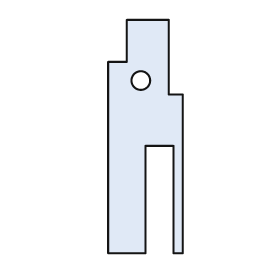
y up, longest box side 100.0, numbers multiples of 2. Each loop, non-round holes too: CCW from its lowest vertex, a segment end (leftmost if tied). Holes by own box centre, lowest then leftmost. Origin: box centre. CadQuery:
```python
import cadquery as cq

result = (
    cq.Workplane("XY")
    .moveTo(-16.0, -50.0)
    .lineTo(0.0, -50.0)
    .lineTo(0.0, -4.0)
    .lineTo(12.0, -4.0)
    .lineTo(12.0, -50.0)
    .lineTo(16.0, -50.0)
    .lineTo(16.0, 18.0)
    .lineTo(10.0, 18.0)
    .lineTo(10.0, 50.0)
    .lineTo(-8.0, 50.0)
    .lineTo(-8.0, 32.0)
    .lineTo(-16.0, 32.0)
    .close()
    .moveTo(-2.0, 24.0)
    .circle(4.0)
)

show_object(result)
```